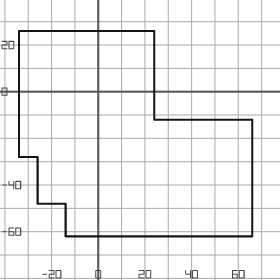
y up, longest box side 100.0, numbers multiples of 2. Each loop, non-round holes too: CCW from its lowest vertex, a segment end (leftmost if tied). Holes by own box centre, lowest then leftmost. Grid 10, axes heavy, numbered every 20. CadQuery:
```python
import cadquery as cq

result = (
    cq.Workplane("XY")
    .moveTo(-14.0, -62.0)
    .lineTo(66.0, -62.0)
    .lineTo(66.0, -12.0)
    .lineTo(24.0, -12.0)
    .lineTo(24.0, 26.0)
    .lineTo(-34.0, 26.0)
    .lineTo(-34.0, -28.0)
    .lineTo(-26.0, -28.0)
    .lineTo(-26.0, -48.0)
    .lineTo(-14.0, -48.0)
    .close()
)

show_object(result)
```